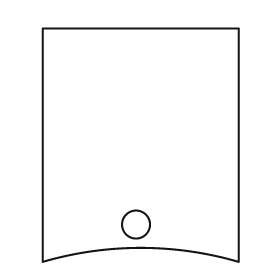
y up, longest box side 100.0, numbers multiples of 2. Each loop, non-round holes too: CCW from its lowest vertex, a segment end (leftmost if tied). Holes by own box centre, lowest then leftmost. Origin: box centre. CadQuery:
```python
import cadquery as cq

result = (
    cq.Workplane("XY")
    .moveTo(-42.0, -50.0)
    .threePointArc((0.0, -44.0), (42.0, -50.0))
    .lineTo(42.0, 50.0)
    .lineTo(-42.0, 50.0)
    .close()
    .moveTo(-2.0, -34.0)
    .circle(6.0)
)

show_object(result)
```